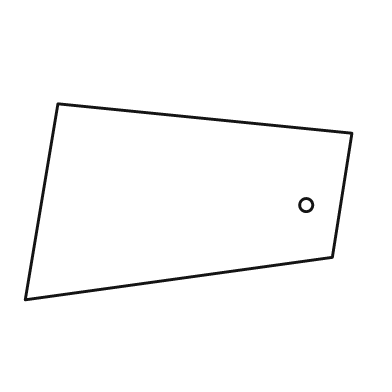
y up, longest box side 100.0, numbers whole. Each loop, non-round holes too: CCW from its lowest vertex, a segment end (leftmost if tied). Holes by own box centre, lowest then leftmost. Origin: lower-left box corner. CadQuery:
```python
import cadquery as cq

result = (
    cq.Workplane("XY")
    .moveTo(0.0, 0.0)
    .lineTo(94.0, 13.0)
    .lineTo(100.0, 51.0)
    .lineTo(10.0, 60.0)
    .close()
    .moveTo(86.0, 29.0)
    .circle(2.0)
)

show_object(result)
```